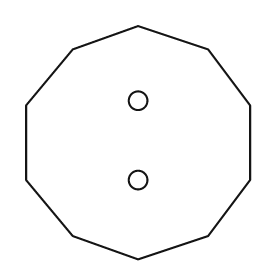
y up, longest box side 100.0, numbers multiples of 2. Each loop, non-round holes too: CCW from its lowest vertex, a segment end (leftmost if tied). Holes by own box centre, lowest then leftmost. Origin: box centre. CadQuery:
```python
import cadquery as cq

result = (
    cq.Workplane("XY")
    .moveTo(0.0, -50.0)
    .lineTo(30.0, -40.0)
    .lineTo(48.0, -16.0)
    .lineTo(48.0, 16.0)
    .lineTo(30.0, 40.0)
    .lineTo(0.0, 50.0)
    .lineTo(-28.0, 40.0)
    .lineTo(-48.0, 16.0)
    .lineTo(-48.0, -16.0)
    .lineTo(-28.0, -40.0)
    .close()
    .moveTo(0.0, -16.0)
    .circle(4.0)
    .moveTo(0.0, 18.0)
    .circle(4.0)
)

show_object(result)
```